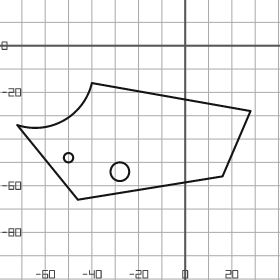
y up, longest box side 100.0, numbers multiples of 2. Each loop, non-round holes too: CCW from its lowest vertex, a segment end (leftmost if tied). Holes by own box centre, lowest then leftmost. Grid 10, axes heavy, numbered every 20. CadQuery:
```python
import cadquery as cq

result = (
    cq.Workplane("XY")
    .moveTo(-46.0, -66.0)
    .lineTo(16.0, -56.0)
    .lineTo(28.0, -28.0)
    .lineTo(-40.0, -16.0)
    .threePointArc((-52.0, -32.0), (-72.0, -34.0))
    .close()
    .moveTo(-28.0, -54.0)
    .circle(4.0)
    .moveTo(-50.0, -48.0)
    .circle(2.0)
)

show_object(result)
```